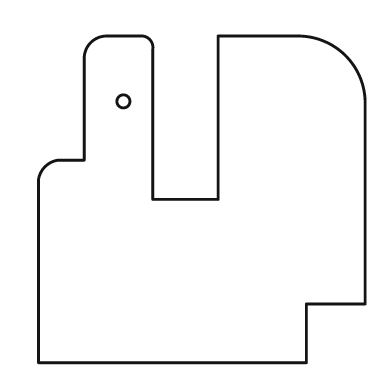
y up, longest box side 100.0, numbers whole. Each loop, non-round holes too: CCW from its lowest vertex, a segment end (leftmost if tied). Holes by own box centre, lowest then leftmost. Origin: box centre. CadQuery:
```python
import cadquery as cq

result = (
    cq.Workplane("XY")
    .moveTo(-50.0, -50.0)
    .lineTo(32.0, -50.0)
    .lineTo(32.0, -32.0)
    .lineTo(50.0, -32.0)
    .lineTo(50.0, 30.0)
    .threePointArc((44.0, 44.0), (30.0, 50.0))
    .lineTo(5.0, 50.0)
    .lineTo(5.0, 0.0)
    .lineTo(-15.0, 0.0)
    .lineTo(-15.0, 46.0)
    .threePointArc((-16.0, 49.0), (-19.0, 50.0))
    .lineTo(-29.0, 50.0)
    .threePointArc((-34.0, 48.0), (-36.0, 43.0))
    .lineTo(-36.0, 12.0)
    .lineTo(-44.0, 12.0)
    .threePointArc((-48.0, 10.0), (-50.0, 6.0))
    .close()
    .moveTo(-24.0, 30.0)
    .circle(2.0)
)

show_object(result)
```